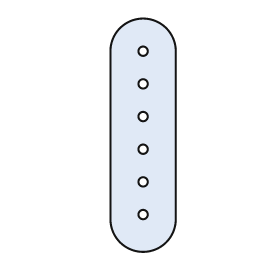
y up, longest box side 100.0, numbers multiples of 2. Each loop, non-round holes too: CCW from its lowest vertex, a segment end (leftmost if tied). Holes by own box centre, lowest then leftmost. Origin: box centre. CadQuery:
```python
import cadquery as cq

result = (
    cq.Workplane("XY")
    .moveTo(-14.0, -36.0)
    .threePointArc((0.0, -50.0), (14.0, -36.0))
    .lineTo(14.0, 36.0)
    .threePointArc((0.0, 50.0), (-14.0, 36.0))
    .close()
    .moveTo(0.0, -34.0)
    .circle(2.0)
    .moveTo(0.0, -20.0)
    .circle(2.0)
    .moveTo(0.0, -6.0)
    .circle(2.0)
    .moveTo(0.0, 8.0)
    .circle(2.0)
    .moveTo(0.0, 22.0)
    .circle(2.0)
    .moveTo(0.0, 36.0)
    .circle(2.0)
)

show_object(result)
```